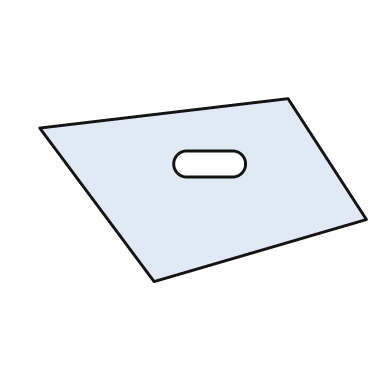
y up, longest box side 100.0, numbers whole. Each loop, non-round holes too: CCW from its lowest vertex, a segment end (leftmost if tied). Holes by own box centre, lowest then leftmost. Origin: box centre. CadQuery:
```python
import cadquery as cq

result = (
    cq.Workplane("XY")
    .moveTo(-15.0, -28.0)
    .lineTo(50.0, -9.0)
    .lineTo(26.0, 28.0)
    .lineTo(-50.0, 19.0)
    .close()
    .moveTo(-5.0, 4.0)
    .lineTo(9.0, 4.0)
    .threePointArc((13.0, 8.0), (9.0, 12.0))
    .lineTo(-5.0, 12.0)
    .threePointArc((-9.0, 8.0), (-5.0, 4.0))
    .close()
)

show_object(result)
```